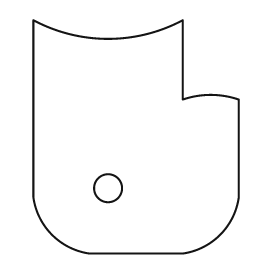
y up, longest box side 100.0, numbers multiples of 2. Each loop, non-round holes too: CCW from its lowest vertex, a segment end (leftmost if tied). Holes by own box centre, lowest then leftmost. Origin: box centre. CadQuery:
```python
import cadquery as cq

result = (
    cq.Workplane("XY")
    .moveTo(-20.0, -50.0)
    .lineTo(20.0, -50.0)
    .threePointArc((36.0, -42.0), (44.0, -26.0))
    .lineTo(44.0, 16.0)
    .threePointArc((32.0, 18.0), (20.0, 16.0))
    .lineTo(20.0, 50.0)
    .threePointArc((-12.0, 42.0), (-44.0, 50.0))
    .lineTo(-44.0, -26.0)
    .threePointArc((-36.0, -42.0), (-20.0, -50.0))
    .close()
    .moveTo(-12.0, -22.0)
    .circle(6.0)
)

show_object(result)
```